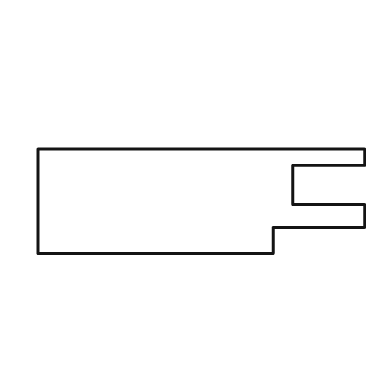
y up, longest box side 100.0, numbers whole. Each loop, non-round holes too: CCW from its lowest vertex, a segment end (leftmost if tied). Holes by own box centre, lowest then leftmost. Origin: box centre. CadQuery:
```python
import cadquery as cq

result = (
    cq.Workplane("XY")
    .moveTo(-50.0, -16.0)
    .lineTo(22.0, -16.0)
    .lineTo(22.0, -8.0)
    .lineTo(50.0, -8.0)
    .lineTo(50.0, -1.0)
    .lineTo(28.0, -1.0)
    .lineTo(28.0, 11.0)
    .lineTo(50.0, 11.0)
    .lineTo(50.0, 16.0)
    .lineTo(-50.0, 16.0)
    .close()
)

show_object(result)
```